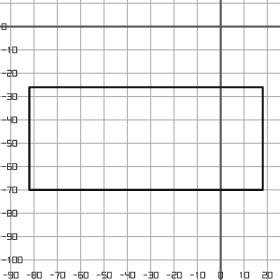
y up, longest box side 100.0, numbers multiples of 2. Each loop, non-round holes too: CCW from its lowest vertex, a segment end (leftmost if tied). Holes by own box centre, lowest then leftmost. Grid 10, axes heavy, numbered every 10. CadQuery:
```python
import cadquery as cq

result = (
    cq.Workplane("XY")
    .moveTo(-82.0, -70.0)
    .lineTo(18.0, -70.0)
    .lineTo(18.0, -26.0)
    .lineTo(-82.0, -26.0)
    .close()
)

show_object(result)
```